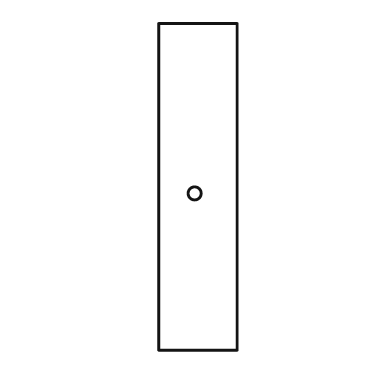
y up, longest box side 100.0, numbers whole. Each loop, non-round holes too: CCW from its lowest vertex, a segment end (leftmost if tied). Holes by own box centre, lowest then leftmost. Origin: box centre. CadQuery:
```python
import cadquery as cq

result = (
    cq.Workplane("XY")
    .moveTo(-12.0, -50.0)
    .lineTo(12.0, -50.0)
    .lineTo(12.0, 50.0)
    .lineTo(-12.0, 50.0)
    .close()
    .moveTo(-1.0, -2.0)
    .circle(2.0)
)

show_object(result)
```